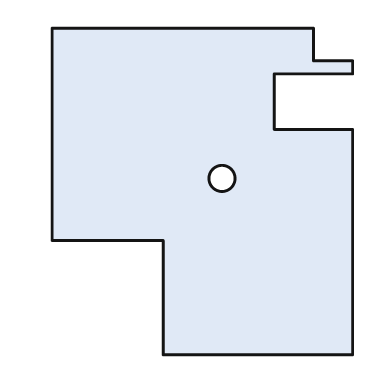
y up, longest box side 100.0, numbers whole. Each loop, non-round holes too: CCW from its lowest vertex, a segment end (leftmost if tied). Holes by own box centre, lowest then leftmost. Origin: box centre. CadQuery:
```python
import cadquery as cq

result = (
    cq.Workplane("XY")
    .moveTo(-12.0, -50.0)
    .lineTo(46.0, -50.0)
    .lineTo(46.0, 19.0)
    .lineTo(22.0, 19.0)
    .lineTo(22.0, 36.0)
    .lineTo(46.0, 36.0)
    .lineTo(46.0, 40.0)
    .lineTo(34.0, 40.0)
    .lineTo(34.0, 50.0)
    .lineTo(-46.0, 50.0)
    .lineTo(-46.0, -15.0)
    .lineTo(-12.0, -15.0)
    .close()
    .moveTo(6.0, 4.0)
    .circle(4.0)
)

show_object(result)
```